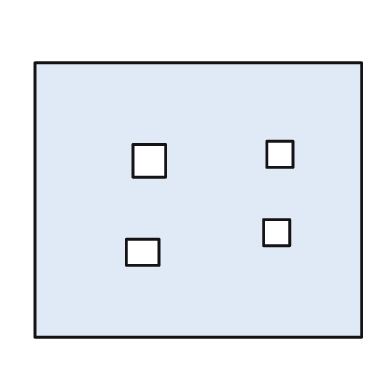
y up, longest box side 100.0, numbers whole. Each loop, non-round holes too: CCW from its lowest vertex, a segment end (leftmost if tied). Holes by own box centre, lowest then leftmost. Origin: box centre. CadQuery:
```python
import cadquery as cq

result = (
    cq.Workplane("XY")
    .moveTo(-50.0, -42.0)
    .lineTo(50.0, -42.0)
    .lineTo(50.0, 42.0)
    .lineTo(-50.0, 42.0)
    .close()
    .moveTo(-22.0, -20.0)
    .lineTo(-12.0, -20.0)
    .lineTo(-12.0, -12.0)
    .lineTo(-22.0, -12.0)
    .close()
    .moveTo(20.0, -14.0)
    .lineTo(28.0, -14.0)
    .lineTo(28.0, -6.0)
    .lineTo(20.0, -6.0)
    .close()
    .moveTo(-20.0, 7.0)
    .lineTo(-10.0, 7.0)
    .lineTo(-10.0, 17.0)
    .lineTo(-20.0, 17.0)
    .close()
    .moveTo(21.0, 10.0)
    .lineTo(29.0, 10.0)
    .lineTo(29.0, 18.0)
    .lineTo(21.0, 18.0)
    .close()
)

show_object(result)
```